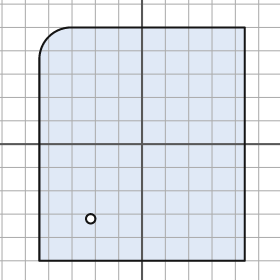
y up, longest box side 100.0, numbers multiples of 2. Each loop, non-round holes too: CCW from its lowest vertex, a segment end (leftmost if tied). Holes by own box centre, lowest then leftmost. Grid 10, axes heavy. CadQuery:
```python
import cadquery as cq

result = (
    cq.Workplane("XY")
    .moveTo(-44.0, -50.0)
    .lineTo(44.0, -50.0)
    .lineTo(44.0, 50.0)
    .lineTo(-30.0, 50.0)
    .threePointArc((-40.0, 46.0), (-44.0, 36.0))
    .close()
    .moveTo(-22.0, -32.0)
    .circle(2.0)
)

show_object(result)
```